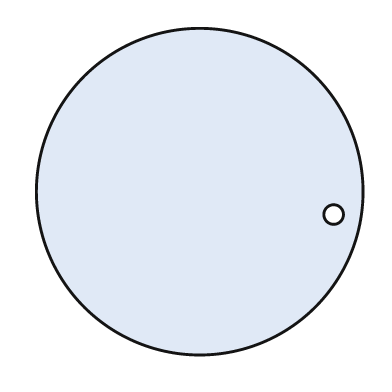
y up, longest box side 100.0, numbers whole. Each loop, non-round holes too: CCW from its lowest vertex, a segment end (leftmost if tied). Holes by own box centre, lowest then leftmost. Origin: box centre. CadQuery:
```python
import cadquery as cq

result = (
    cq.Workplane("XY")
    .moveTo(0.0, 0.0)
    .circle(50.0)
    .moveTo(41.0, -7.0)
    .circle(3.0)
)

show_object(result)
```